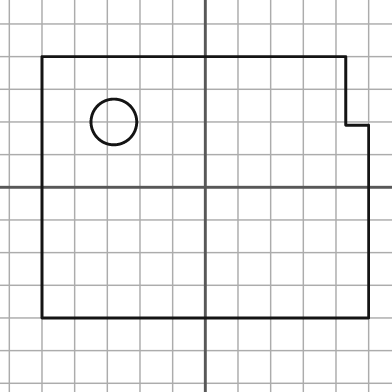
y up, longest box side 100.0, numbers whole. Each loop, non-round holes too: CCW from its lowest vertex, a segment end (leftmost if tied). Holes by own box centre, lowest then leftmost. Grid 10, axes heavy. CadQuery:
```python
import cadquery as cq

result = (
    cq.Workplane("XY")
    .moveTo(-50.0, -40.0)
    .lineTo(50.0, -40.0)
    .lineTo(50.0, 19.0)
    .lineTo(43.0, 19.0)
    .lineTo(43.0, 40.0)
    .lineTo(-50.0, 40.0)
    .close()
    .moveTo(-28.0, 20.0)
    .circle(7.0)
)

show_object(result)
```